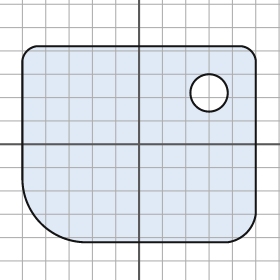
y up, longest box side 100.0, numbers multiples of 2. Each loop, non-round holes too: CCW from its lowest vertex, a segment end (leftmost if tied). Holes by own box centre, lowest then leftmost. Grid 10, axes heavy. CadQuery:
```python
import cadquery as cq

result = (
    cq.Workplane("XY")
    .moveTo(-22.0, -42.0)
    .lineTo(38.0, -42.0)
    .threePointArc((46.0, -38.0), (50.0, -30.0))
    .lineTo(50.0, 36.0)
    .threePointArc((48.0, 40.0), (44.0, 42.0))
    .lineTo(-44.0, 42.0)
    .threePointArc((-48.0, 40.0), (-50.0, 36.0))
    .lineTo(-50.0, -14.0)
    .threePointArc((-42.0, -34.0), (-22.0, -42.0))
    .close()
    .moveTo(30.0, 22.0)
    .circle(8.0)
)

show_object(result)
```